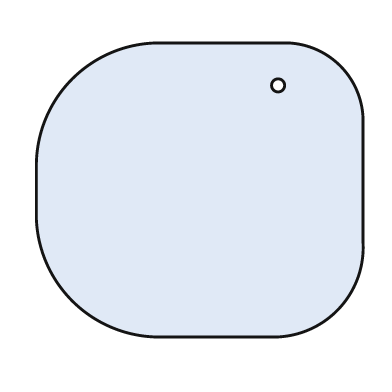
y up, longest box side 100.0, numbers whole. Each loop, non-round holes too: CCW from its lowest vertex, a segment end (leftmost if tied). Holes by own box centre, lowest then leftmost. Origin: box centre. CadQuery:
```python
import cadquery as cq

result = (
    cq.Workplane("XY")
    .moveTo(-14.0, -45.0)
    .lineTo(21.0, -45.0)
    .threePointArc((42.0, -37.0), (50.0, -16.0))
    .lineTo(50.0, 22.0)
    .threePointArc((43.0, 38.0), (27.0, 45.0))
    .lineTo(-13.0, 45.0)
    .threePointArc((-39.0, 34.0), (-50.0, 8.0))
    .lineTo(-50.0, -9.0)
    .threePointArc((-39.0, -34.0), (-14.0, -45.0))
    .close()
    .moveTo(24.0, 32.0)
    .circle(2.0)
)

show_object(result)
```